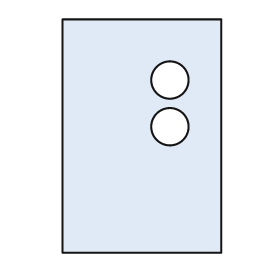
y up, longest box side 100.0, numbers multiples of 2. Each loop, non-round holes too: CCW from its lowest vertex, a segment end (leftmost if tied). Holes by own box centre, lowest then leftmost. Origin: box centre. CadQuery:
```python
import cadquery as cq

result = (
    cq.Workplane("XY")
    .moveTo(-34.0, -50.0)
    .lineTo(34.0, -50.0)
    .lineTo(34.0, 50.0)
    .lineTo(-34.0, 50.0)
    .close()
    .moveTo(12.0, 4.0)
    .circle(8.0)
    .moveTo(12.0, 24.0)
    .circle(8.0)
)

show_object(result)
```